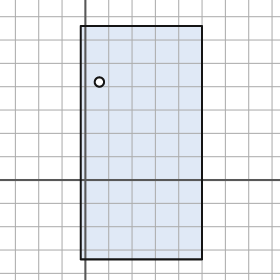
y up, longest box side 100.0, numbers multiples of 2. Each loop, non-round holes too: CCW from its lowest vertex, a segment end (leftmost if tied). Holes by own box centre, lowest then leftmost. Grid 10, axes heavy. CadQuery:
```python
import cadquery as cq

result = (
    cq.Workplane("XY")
    .moveTo(-2.0, -34.0)
    .lineTo(50.0, -34.0)
    .lineTo(50.0, 66.0)
    .lineTo(-2.0, 66.0)
    .close()
    .moveTo(6.0, 42.0)
    .circle(2.0)
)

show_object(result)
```